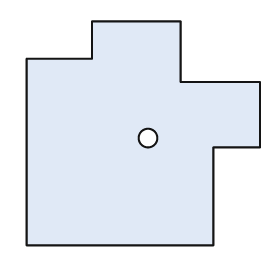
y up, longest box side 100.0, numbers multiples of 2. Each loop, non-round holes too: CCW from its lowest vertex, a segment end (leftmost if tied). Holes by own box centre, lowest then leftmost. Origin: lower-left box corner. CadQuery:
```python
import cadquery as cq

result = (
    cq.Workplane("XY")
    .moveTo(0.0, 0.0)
    .lineTo(80.0, 0.0)
    .lineTo(80.0, 42.0)
    .lineTo(100.0, 42.0)
    .lineTo(100.0, 70.0)
    .lineTo(66.0, 70.0)
    .lineTo(66.0, 96.0)
    .lineTo(28.0, 96.0)
    .lineTo(28.0, 80.0)
    .lineTo(0.0, 80.0)
    .close()
    .moveTo(52.0, 46.0)
    .circle(4.0)
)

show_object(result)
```